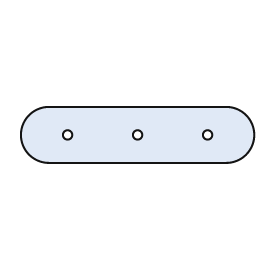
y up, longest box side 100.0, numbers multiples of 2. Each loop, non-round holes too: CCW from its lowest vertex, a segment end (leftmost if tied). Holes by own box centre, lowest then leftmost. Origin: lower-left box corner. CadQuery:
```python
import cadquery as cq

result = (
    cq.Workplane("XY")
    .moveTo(12.0, 0.0)
    .lineTo(88.0, 0.0)
    .threePointArc((100.0, 12.0), (88.0, 24.0))
    .lineTo(12.0, 24.0)
    .threePointArc((0.0, 12.0), (12.0, 0.0))
    .close()
    .moveTo(20.0, 12.0)
    .circle(2.0)
    .moveTo(50.0, 12.0)
    .circle(2.0)
    .moveTo(80.0, 12.0)
    .circle(2.0)
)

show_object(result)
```